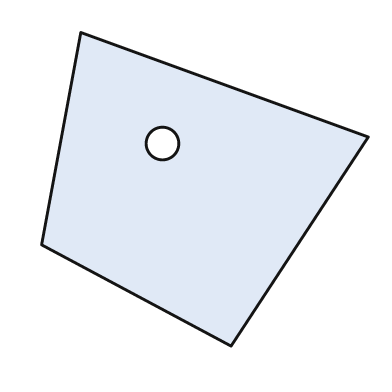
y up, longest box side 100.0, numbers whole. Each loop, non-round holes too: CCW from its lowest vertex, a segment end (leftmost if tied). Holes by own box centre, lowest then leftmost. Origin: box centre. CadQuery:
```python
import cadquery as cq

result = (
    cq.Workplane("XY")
    .moveTo(8.0, -48.0)
    .lineTo(50.0, 16.0)
    .lineTo(-38.0, 48.0)
    .lineTo(-50.0, -17.0)
    .close()
    .moveTo(-13.0, 14.0)
    .circle(5.0)
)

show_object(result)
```